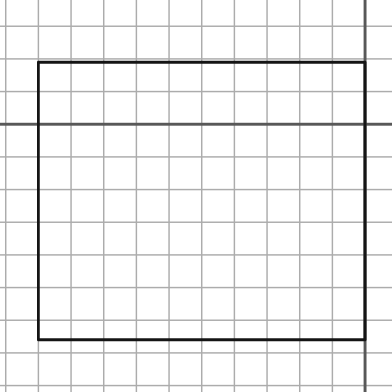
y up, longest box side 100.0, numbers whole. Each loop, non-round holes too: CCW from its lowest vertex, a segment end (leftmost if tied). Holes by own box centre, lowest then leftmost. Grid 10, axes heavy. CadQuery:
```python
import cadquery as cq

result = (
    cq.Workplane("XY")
    .moveTo(-100.0, -66.0)
    .lineTo(0.0, -66.0)
    .lineTo(0.0, 19.0)
    .lineTo(-100.0, 19.0)
    .close()
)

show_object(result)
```